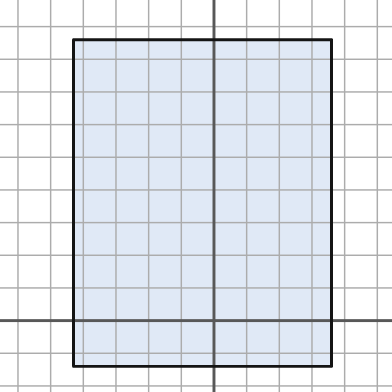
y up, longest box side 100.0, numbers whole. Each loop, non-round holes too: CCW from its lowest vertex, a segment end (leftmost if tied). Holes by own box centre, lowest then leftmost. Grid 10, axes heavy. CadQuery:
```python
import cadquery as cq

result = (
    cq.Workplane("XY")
    .moveTo(-43.0, -14.0)
    .lineTo(36.0, -14.0)
    .lineTo(36.0, 86.0)
    .lineTo(-43.0, 86.0)
    .close()
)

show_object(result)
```